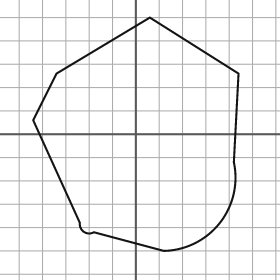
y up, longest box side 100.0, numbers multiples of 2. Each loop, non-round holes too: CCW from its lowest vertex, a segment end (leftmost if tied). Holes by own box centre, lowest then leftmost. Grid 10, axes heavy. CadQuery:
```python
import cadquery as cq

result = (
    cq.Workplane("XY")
    .moveTo(12.0, -50.0)
    .threePointArc((36.0, -38.0), (42.0, -12.0))
    .lineTo(44.0, 26.0)
    .lineTo(6.0, 50.0)
    .lineTo(-34.0, 26.0)
    .lineTo(-44.0, 6.0)
    .lineTo(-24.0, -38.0)
    .threePointArc((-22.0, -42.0), (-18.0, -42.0))
    .close()
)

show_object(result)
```